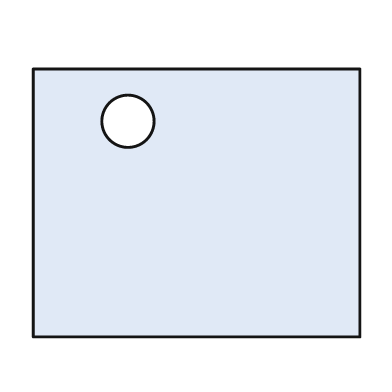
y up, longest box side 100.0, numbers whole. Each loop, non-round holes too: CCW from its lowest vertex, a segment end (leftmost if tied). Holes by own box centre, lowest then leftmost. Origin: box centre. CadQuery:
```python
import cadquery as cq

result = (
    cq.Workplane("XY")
    .moveTo(-50.0, -41.0)
    .lineTo(50.0, -41.0)
    .lineTo(50.0, 41.0)
    .lineTo(-50.0, 41.0)
    .close()
    .moveTo(-21.0, 25.0)
    .circle(8.0)
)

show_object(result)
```